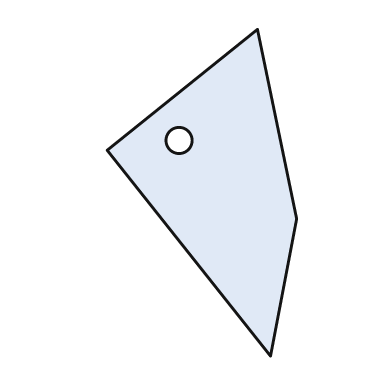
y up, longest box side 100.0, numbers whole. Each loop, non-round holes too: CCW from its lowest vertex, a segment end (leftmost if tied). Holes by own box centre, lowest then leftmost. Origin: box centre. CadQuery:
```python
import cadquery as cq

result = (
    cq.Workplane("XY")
    .moveTo(21.0, -50.0)
    .lineTo(29.0, -8.0)
    .lineTo(17.0, 50.0)
    .lineTo(-29.0, 13.0)
    .close()
    .moveTo(-7.0, 16.0)
    .circle(4.0)
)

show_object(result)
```